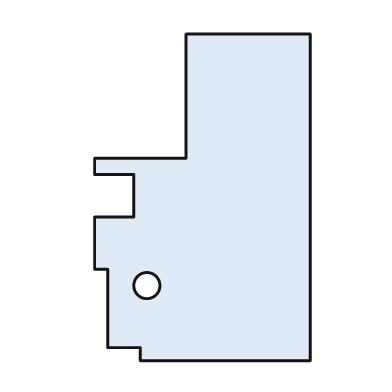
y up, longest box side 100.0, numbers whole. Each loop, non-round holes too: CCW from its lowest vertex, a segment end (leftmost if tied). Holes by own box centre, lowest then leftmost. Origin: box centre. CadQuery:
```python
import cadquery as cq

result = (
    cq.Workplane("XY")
    .moveTo(-19.0, -50.0)
    .lineTo(33.0, -50.0)
    .lineTo(33.0, 50.0)
    .lineTo(-5.0, 50.0)
    .lineTo(-5.0, 12.0)
    .lineTo(-33.0, 12.0)
    .lineTo(-33.0, 7.0)
    .lineTo(-21.0, 7.0)
    .lineTo(-21.0, -6.0)
    .lineTo(-33.0, -6.0)
    .lineTo(-33.0, -22.0)
    .lineTo(-29.0, -22.0)
    .lineTo(-29.0, -46.0)
    .lineTo(-19.0, -46.0)
    .close()
    .moveTo(-17.0, -27.0)
    .circle(4.0)
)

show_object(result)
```